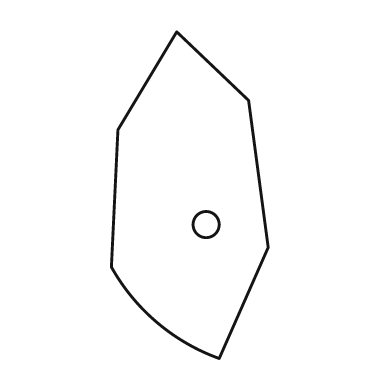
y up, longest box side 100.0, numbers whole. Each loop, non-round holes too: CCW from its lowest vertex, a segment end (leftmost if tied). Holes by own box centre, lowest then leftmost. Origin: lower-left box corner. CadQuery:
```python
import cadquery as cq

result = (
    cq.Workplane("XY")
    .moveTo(33.0, 0.0)
    .lineTo(48.0, 34.0)
    .lineTo(42.0, 79.0)
    .lineTo(20.0, 100.0)
    .lineTo(2.0, 70.0)
    .lineTo(0.0, 28.0)
    .threePointArc((14.0, 11.0), (33.0, 0.0))
    .close()
    .moveTo(29.0, 41.0)
    .circle(4.0)
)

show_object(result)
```